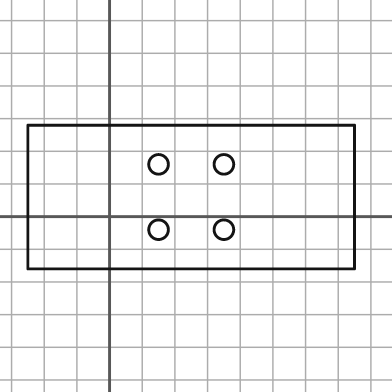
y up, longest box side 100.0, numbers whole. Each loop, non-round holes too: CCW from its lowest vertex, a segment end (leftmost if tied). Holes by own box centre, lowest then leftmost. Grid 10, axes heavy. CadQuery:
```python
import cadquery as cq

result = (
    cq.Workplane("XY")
    .moveTo(-25.0, -16.0)
    .lineTo(75.0, -16.0)
    .lineTo(75.0, 28.0)
    .lineTo(-25.0, 28.0)
    .close()
    .moveTo(15.0, -4.0)
    .circle(3.0)
    .moveTo(35.0, -4.0)
    .circle(3.0)
    .moveTo(15.0, 16.0)
    .circle(3.0)
    .moveTo(35.0, 16.0)
    .circle(3.0)
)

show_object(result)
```